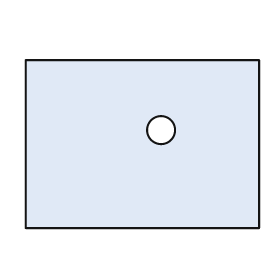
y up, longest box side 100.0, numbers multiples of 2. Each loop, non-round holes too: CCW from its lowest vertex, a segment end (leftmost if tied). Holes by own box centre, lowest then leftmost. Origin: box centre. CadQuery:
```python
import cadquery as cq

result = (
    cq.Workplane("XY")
    .moveTo(-50.0, -36.0)
    .lineTo(50.0, -36.0)
    .lineTo(50.0, 36.0)
    .lineTo(-50.0, 36.0)
    .close()
    .moveTo(8.0, 6.0)
    .circle(6.0)
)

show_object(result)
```